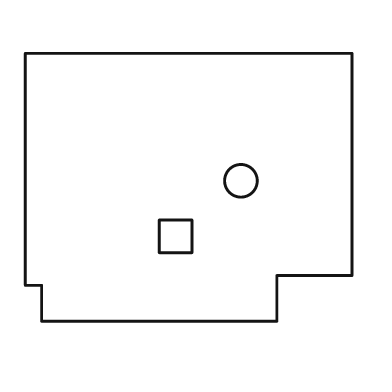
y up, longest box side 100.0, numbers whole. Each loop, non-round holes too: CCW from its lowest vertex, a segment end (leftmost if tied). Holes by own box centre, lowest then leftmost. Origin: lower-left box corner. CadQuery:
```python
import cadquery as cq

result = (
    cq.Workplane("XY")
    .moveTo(5.0, 0.0)
    .lineTo(77.0, 0.0)
    .lineTo(77.0, 14.0)
    .lineTo(100.0, 14.0)
    .lineTo(100.0, 82.0)
    .lineTo(0.0, 82.0)
    .lineTo(0.0, 11.0)
    .lineTo(5.0, 11.0)
    .close()
    .moveTo(41.0, 21.0)
    .lineTo(51.0, 21.0)
    .lineTo(51.0, 31.0)
    .lineTo(41.0, 31.0)
    .close()
    .moveTo(66.0, 43.0)
    .circle(5.0)
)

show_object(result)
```